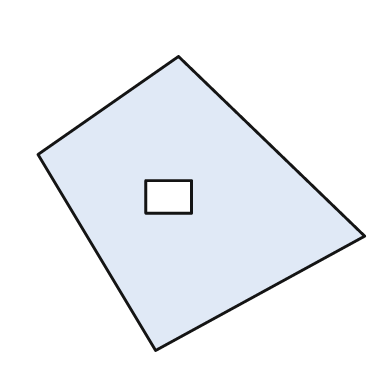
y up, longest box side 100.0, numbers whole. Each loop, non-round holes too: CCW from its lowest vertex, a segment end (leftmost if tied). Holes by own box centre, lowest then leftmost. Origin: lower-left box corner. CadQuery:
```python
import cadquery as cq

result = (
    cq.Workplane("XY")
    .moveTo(36.0, 0.0)
    .lineTo(100.0, 35.0)
    .lineTo(43.0, 90.0)
    .lineTo(0.0, 60.0)
    .close()
    .moveTo(33.0, 42.0)
    .lineTo(47.0, 42.0)
    .lineTo(47.0, 52.0)
    .lineTo(33.0, 52.0)
    .close()
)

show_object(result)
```